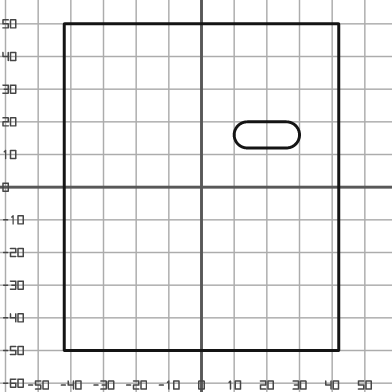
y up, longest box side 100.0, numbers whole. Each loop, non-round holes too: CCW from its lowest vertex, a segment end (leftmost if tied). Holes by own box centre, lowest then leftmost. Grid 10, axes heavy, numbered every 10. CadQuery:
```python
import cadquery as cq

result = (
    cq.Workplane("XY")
    .moveTo(-42.0, -50.0)
    .lineTo(42.0, -50.0)
    .lineTo(42.0, 50.0)
    .lineTo(-42.0, 50.0)
    .close()
    .moveTo(14.0, 12.0)
    .lineTo(26.0, 12.0)
    .threePointArc((30.0, 16.0), (26.0, 20.0))
    .lineTo(14.0, 20.0)
    .threePointArc((10.0, 16.0), (14.0, 12.0))
    .close()
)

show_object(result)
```